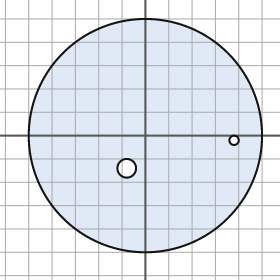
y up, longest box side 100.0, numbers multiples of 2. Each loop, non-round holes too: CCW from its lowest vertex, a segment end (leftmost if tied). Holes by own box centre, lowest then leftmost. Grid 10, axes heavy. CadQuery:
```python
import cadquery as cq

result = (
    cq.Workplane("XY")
    .moveTo(0.0, 0.0)
    .circle(50.0)
    .moveTo(-8.0, -14.0)
    .circle(4.0)
    .moveTo(38.0, -2.0)
    .circle(2.0)
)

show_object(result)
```